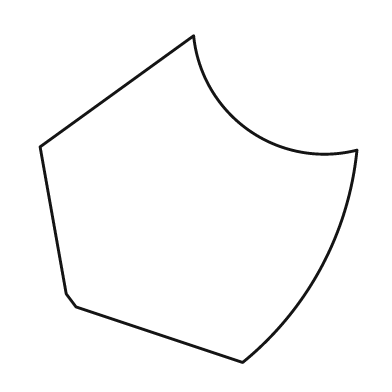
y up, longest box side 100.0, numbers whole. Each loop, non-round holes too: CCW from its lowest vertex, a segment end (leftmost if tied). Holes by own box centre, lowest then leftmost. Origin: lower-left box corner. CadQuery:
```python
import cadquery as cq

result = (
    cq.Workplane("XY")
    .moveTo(62.0, 0.0)
    .threePointArc((86.0, 29.0), (97.0, 65.0))
    .threePointArc((64.0, 71.0), (47.0, 100.0))
    .lineTo(0.0, 66.0)
    .lineTo(8.0, 21.0)
    .lineTo(11.0, 17.0)
    .close()
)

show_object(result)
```